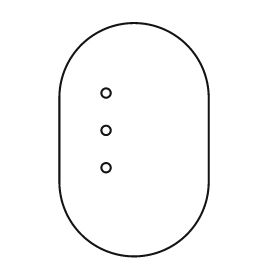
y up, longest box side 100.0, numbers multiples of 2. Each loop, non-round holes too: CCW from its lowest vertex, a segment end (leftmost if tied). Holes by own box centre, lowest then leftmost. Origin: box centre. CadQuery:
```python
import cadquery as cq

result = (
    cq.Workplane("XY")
    .moveTo(-32.0, -18.0)
    .threePointArc((0.0, -50.0), (32.0, -18.0))
    .lineTo(32.0, 18.0)
    .threePointArc((0.0, 50.0), (-32.0, 18.0))
    .close()
    .moveTo(-12.0, -12.0)
    .circle(2.0)
    .moveTo(-12.0, 4.0)
    .circle(2.0)
    .moveTo(-12.0, 20.0)
    .circle(2.0)
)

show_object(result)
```